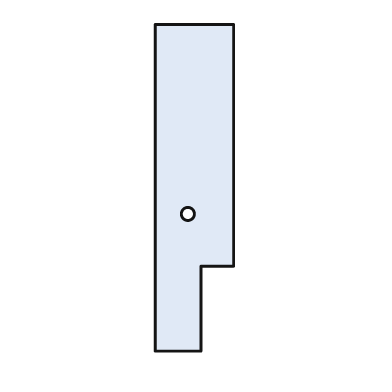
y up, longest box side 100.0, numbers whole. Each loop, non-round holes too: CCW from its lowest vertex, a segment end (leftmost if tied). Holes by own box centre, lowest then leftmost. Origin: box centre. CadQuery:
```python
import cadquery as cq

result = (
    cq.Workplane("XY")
    .moveTo(-12.0, -50.0)
    .lineTo(2.0, -50.0)
    .lineTo(2.0, -24.0)
    .lineTo(12.0, -24.0)
    .lineTo(12.0, 50.0)
    .lineTo(-12.0, 50.0)
    .close()
    .moveTo(-2.0, -8.0)
    .circle(2.0)
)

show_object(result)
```